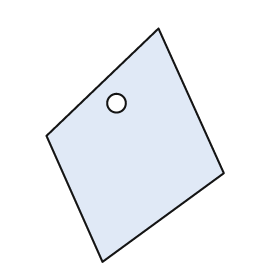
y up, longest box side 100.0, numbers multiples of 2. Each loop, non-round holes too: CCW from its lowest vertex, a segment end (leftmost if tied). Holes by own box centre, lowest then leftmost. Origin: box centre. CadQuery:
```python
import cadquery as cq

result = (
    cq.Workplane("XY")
    .moveTo(-14.0, -50.0)
    .lineTo(38.0, -12.0)
    .lineTo(10.0, 50.0)
    .lineTo(-38.0, 4.0)
    .close()
    .moveTo(-8.0, 18.0)
    .circle(4.0)
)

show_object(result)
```